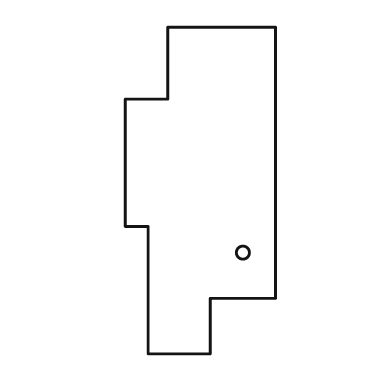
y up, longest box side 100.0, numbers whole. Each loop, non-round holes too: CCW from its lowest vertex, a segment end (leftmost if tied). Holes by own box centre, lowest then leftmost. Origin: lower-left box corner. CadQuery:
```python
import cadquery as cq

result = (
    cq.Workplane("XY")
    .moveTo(7.0, 0.0)
    .lineTo(26.0, 0.0)
    .lineTo(26.0, 17.0)
    .lineTo(46.0, 17.0)
    .lineTo(46.0, 100.0)
    .lineTo(13.0, 100.0)
    .lineTo(13.0, 78.0)
    .lineTo(0.0, 78.0)
    .lineTo(0.0, 39.0)
    .lineTo(7.0, 39.0)
    .close()
    .moveTo(36.0, 31.0)
    .circle(2.0)
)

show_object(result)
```